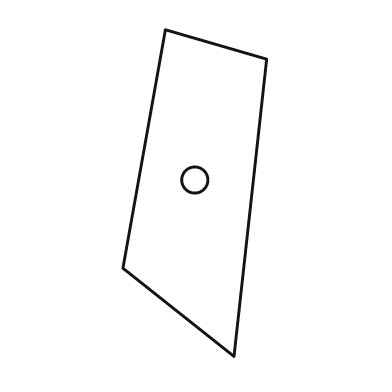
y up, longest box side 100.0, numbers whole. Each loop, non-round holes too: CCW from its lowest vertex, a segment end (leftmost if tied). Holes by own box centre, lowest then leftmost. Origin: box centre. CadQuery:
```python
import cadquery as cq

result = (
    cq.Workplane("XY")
    .moveTo(12.0, -50.0)
    .lineTo(22.0, 41.0)
    .lineTo(-9.0, 50.0)
    .lineTo(-22.0, -23.0)
    .close()
    .moveTo(0.0, 4.0)
    .circle(4.0)
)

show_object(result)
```